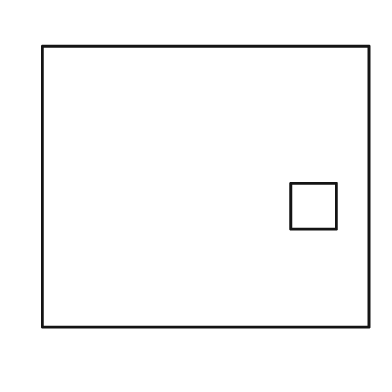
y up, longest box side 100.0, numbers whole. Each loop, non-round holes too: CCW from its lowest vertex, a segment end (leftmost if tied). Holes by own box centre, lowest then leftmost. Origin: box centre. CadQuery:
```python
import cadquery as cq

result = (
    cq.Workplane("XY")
    .moveTo(-50.0, -43.0)
    .lineTo(50.0, -43.0)
    .lineTo(50.0, 43.0)
    .lineTo(-50.0, 43.0)
    .close()
    .moveTo(26.0, -13.0)
    .lineTo(40.0, -13.0)
    .lineTo(40.0, 1.0)
    .lineTo(26.0, 1.0)
    .close()
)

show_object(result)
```